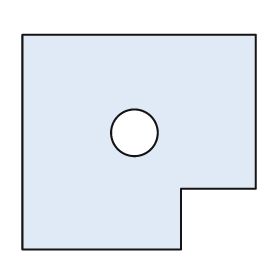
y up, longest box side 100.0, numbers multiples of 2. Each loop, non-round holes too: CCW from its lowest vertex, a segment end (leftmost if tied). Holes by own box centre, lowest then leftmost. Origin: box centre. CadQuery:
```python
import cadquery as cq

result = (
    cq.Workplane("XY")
    .moveTo(-50.0, -46.0)
    .lineTo(18.0, -46.0)
    .lineTo(18.0, -20.0)
    .lineTo(50.0, -20.0)
    .lineTo(50.0, 46.0)
    .lineTo(-50.0, 46.0)
    .close()
    .moveTo(-2.0, 4.0)
    .circle(10.0)
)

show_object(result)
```